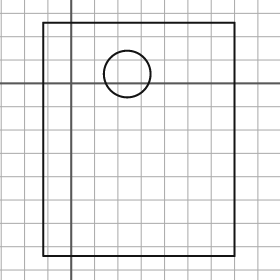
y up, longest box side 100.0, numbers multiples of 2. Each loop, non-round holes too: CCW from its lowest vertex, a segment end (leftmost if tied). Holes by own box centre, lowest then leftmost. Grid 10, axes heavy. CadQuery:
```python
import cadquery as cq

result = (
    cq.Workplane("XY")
    .moveTo(-12.0, -74.0)
    .lineTo(70.0, -74.0)
    .lineTo(70.0, 26.0)
    .lineTo(-12.0, 26.0)
    .close()
    .moveTo(24.0, 4.0)
    .circle(10.0)
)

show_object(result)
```